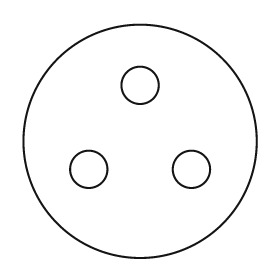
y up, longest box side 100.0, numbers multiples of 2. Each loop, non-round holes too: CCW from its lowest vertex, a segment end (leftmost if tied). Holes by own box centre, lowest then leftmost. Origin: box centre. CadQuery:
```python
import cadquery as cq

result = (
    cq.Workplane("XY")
    .moveTo(0.0, 0.0)
    .circle(50.0)
    .moveTo(-22.0, -12.0)
    .circle(8.0)
    .moveTo(22.0, -12.0)
    .circle(8.0)
    .moveTo(0.0, 24.0)
    .circle(8.0)
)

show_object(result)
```